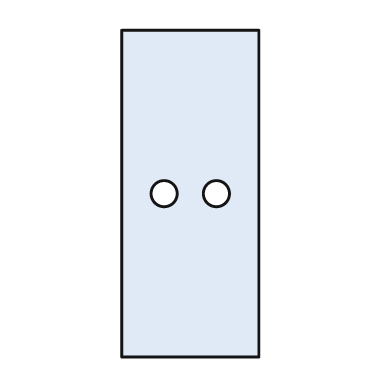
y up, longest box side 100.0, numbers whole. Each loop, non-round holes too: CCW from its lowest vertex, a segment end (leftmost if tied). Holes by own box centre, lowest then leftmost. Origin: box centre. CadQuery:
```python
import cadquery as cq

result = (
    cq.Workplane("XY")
    .moveTo(-21.0, -50.0)
    .lineTo(21.0, -50.0)
    .lineTo(21.0, 50.0)
    .lineTo(-21.0, 50.0)
    .close()
    .moveTo(-8.0, 0.0)
    .circle(4.0)
    .moveTo(8.0, 0.0)
    .circle(4.0)
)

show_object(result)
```